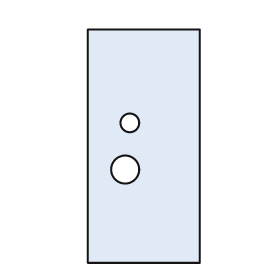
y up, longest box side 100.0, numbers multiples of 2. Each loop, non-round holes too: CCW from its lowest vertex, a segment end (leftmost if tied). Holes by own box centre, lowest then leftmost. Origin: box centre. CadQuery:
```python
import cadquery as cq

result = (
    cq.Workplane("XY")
    .moveTo(-24.0, -50.0)
    .lineTo(24.0, -50.0)
    .lineTo(24.0, 50.0)
    .lineTo(-24.0, 50.0)
    .close()
    .moveTo(-8.0, -10.0)
    .circle(6.0)
    .moveTo(-6.0, 10.0)
    .circle(4.0)
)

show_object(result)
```